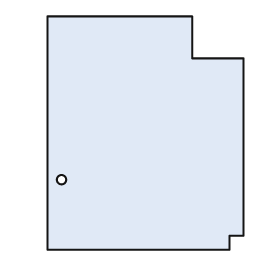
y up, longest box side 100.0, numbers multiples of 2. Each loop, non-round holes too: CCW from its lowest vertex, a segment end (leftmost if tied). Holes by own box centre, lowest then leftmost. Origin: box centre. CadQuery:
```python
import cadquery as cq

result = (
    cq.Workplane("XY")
    .moveTo(-42.0, -50.0)
    .lineTo(36.0, -50.0)
    .lineTo(36.0, -44.0)
    .lineTo(42.0, -44.0)
    .lineTo(42.0, 32.0)
    .lineTo(20.0, 32.0)
    .lineTo(20.0, 50.0)
    .lineTo(-42.0, 50.0)
    .close()
    .moveTo(-36.0, -20.0)
    .circle(2.0)
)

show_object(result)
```